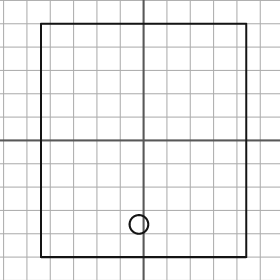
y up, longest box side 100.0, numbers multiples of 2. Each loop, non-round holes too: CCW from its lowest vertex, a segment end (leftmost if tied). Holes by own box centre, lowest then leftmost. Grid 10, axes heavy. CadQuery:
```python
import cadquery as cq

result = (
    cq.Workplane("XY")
    .moveTo(-44.0, -50.0)
    .lineTo(44.0, -50.0)
    .lineTo(44.0, 50.0)
    .lineTo(-44.0, 50.0)
    .close()
    .moveTo(-2.0, -36.0)
    .circle(4.0)
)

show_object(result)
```